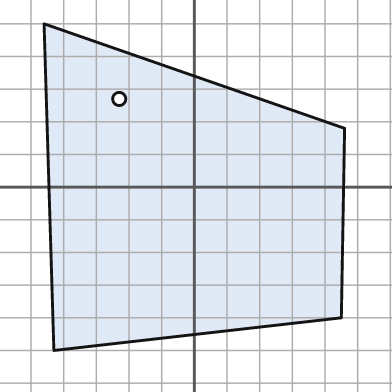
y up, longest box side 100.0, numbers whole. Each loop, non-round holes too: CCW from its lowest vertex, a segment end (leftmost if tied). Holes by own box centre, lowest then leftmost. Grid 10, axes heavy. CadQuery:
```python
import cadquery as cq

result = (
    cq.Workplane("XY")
    .moveTo(-43.0, -50.0)
    .lineTo(45.0, -40.0)
    .lineTo(46.0, 18.0)
    .lineTo(-46.0, 50.0)
    .close()
    .moveTo(-23.0, 27.0)
    .circle(2.0)
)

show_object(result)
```